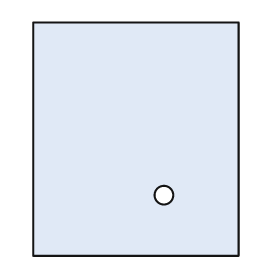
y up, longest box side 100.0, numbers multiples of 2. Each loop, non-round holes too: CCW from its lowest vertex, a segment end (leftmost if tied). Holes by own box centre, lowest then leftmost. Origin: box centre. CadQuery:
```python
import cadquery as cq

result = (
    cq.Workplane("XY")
    .moveTo(-44.0, -50.0)
    .lineTo(44.0, -50.0)
    .lineTo(44.0, 50.0)
    .lineTo(-44.0, 50.0)
    .close()
    .moveTo(12.0, -24.0)
    .circle(4.0)
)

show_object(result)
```